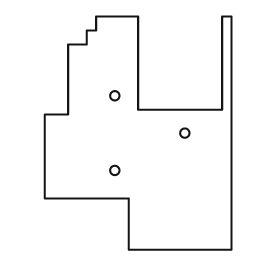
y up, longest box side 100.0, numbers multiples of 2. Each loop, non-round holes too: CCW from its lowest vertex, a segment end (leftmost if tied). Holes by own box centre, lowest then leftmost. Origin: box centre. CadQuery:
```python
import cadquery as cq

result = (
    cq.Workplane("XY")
    .moveTo(-4.0, -50.0)
    .lineTo(40.0, -50.0)
    .lineTo(40.0, 50.0)
    .lineTo(36.0, 50.0)
    .lineTo(36.0, 10.0)
    .lineTo(0.0, 10.0)
    .lineTo(0.0, 50.0)
    .lineTo(-18.0, 50.0)
    .lineTo(-18.0, 44.0)
    .lineTo(-22.0, 44.0)
    .lineTo(-22.0, 38.0)
    .lineTo(-30.0, 38.0)
    .lineTo(-30.0, 8.0)
    .lineTo(-40.0, 8.0)
    .lineTo(-40.0, -28.0)
    .lineTo(-4.0, -28.0)
    .close()
    .moveTo(-10.0, -16.0)
    .circle(2.0)
    .moveTo(20.0, 0.0)
    .circle(2.0)
    .moveTo(-10.0, 16.0)
    .circle(2.0)
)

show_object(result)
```